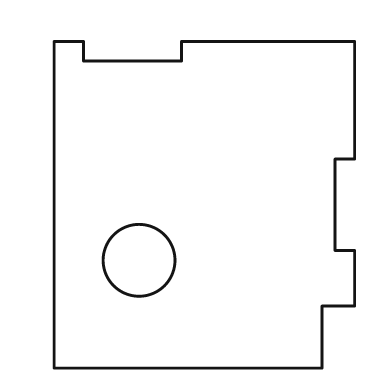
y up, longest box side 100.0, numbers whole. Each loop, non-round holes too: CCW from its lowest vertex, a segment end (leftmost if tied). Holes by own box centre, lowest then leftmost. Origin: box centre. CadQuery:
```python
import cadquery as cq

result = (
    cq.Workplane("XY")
    .moveTo(-46.0, -50.0)
    .lineTo(36.0, -50.0)
    .lineTo(36.0, -31.0)
    .lineTo(46.0, -31.0)
    .lineTo(46.0, -14.0)
    .lineTo(40.0, -14.0)
    .lineTo(40.0, 14.0)
    .lineTo(46.0, 14.0)
    .lineTo(46.0, 50.0)
    .lineTo(-7.0, 50.0)
    .lineTo(-7.0, 44.0)
    .lineTo(-37.0, 44.0)
    .lineTo(-37.0, 50.0)
    .lineTo(-46.0, 50.0)
    .close()
    .moveTo(-20.0, -17.0)
    .circle(11.0)
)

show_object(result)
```